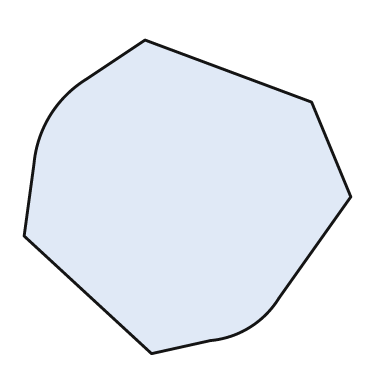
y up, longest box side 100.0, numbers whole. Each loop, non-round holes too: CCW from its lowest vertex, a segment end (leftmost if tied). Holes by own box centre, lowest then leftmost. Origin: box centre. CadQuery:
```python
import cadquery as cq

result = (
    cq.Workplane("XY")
    .moveTo(-11.0, -48.0)
    .lineTo(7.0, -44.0)
    .threePointArc((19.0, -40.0), (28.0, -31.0))
    .lineTo(50.0, 0.0)
    .lineTo(38.0, 29.0)
    .lineTo(-13.0, 48.0)
    .lineTo(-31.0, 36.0)
    .threePointArc((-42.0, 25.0), (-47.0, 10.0))
    .lineTo(-50.0, -12.0)
    .close()
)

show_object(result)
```